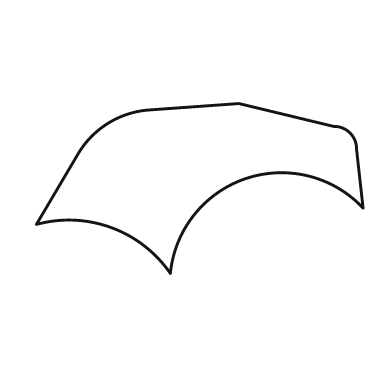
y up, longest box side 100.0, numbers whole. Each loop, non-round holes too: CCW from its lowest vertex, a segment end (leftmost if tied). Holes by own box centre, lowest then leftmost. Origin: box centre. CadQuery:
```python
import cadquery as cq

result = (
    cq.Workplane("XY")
    .moveTo(-9.0, -26.0)
    .threePointArc((14.0, 3.0), (50.0, -6.0))
    .lineTo(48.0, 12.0)
    .threePointArc((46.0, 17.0), (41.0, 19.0))
    .lineTo(12.0, 26.0)
    .lineTo(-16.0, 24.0)
    .threePointArc((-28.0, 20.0), (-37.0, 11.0))
    .lineTo(-50.0, -11.0)
    .threePointArc((-27.0, -12.0), (-9.0, -26.0))
    .close()
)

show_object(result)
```